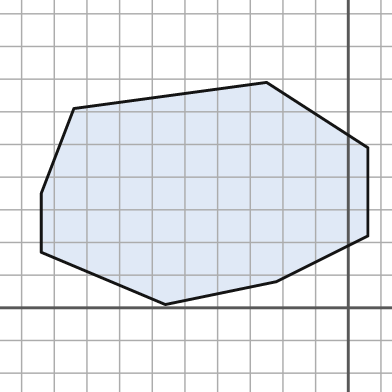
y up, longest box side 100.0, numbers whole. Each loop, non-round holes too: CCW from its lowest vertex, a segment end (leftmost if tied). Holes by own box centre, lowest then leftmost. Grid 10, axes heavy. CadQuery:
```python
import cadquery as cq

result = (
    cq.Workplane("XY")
    .moveTo(-56.0, 1.0)
    .lineTo(-22.0, 8.0)
    .lineTo(6.0, 22.0)
    .lineTo(6.0, 49.0)
    .lineTo(-25.0, 69.0)
    .lineTo(-84.0, 61.0)
    .lineTo(-94.0, 35.0)
    .lineTo(-94.0, 17.0)
    .close()
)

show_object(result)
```